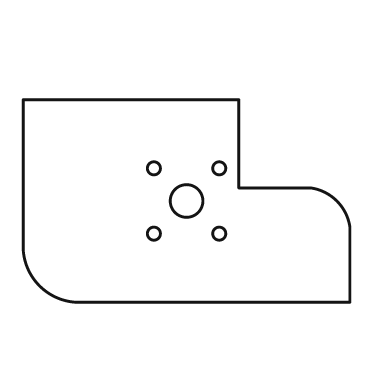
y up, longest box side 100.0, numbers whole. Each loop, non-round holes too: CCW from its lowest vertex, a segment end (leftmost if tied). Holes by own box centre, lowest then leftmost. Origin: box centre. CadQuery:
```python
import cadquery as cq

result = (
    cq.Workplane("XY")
    .moveTo(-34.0, -31.0)
    .lineTo(50.0, -31.0)
    .lineTo(50.0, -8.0)
    .threePointArc((46.0, 0.0), (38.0, 4.0))
    .lineTo(16.0, 4.0)
    .lineTo(16.0, 31.0)
    .lineTo(-50.0, 31.0)
    .lineTo(-50.0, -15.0)
    .threePointArc((-45.0, -26.0), (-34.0, -31.0))
    .close()
    .moveTo(-10.0, -10.0)
    .circle(2.0)
    .moveTo(10.0, -10.0)
    .circle(2.0)
    .moveTo(0.0, 0.0)
    .circle(5.0)
    .moveTo(-10.0, 10.0)
    .circle(2.0)
    .moveTo(10.0, 10.0)
    .circle(2.0)
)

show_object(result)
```